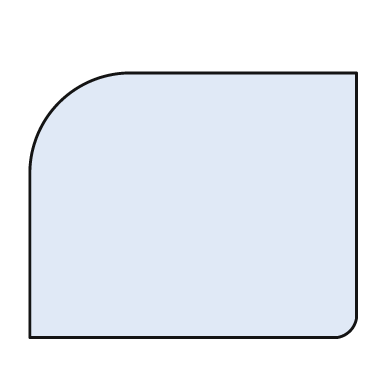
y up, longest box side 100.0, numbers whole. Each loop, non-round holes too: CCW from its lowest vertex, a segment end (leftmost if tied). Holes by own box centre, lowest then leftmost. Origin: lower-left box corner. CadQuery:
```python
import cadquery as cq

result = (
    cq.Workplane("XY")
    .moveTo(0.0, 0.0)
    .lineTo(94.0, 0.0)
    .threePointArc((98.0, 2.0), (100.0, 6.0))
    .lineTo(100.0, 81.0)
    .lineTo(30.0, 81.0)
    .threePointArc((9.0, 72.0), (0.0, 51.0))
    .close()
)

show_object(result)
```